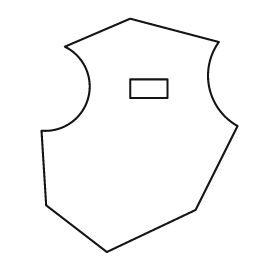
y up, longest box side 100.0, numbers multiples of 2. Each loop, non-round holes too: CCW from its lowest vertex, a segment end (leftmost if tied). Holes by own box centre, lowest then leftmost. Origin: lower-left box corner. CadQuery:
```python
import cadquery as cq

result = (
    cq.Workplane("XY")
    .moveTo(28.0, 0.0)
    .lineTo(66.0, 18.0)
    .lineTo(84.0, 54.0)
    .threePointArc((72.0, 70.0), (76.0, 90.0))
    .lineTo(38.0, 100.0)
    .lineTo(10.0, 88.0)
    .threePointArc((20.0, 66.0), (0.0, 52.0))
    .lineTo(2.0, 20.0)
    .close()
    .moveTo(38.0, 66.0)
    .lineTo(54.0, 66.0)
    .lineTo(54.0, 74.0)
    .lineTo(38.0, 74.0)
    .close()
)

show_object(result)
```